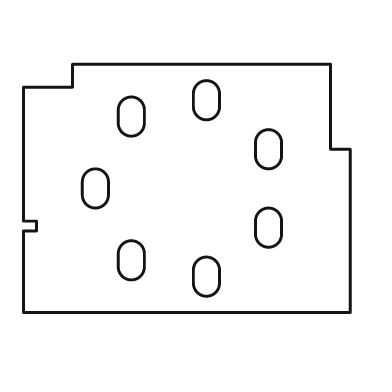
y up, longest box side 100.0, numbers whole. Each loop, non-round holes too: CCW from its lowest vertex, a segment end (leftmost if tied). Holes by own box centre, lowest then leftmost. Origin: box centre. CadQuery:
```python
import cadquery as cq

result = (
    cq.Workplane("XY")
    .moveTo(-50.0, -38.0)
    .lineTo(50.0, -38.0)
    .lineTo(50.0, 12.0)
    .lineTo(44.0, 12.0)
    .lineTo(44.0, 38.0)
    .lineTo(-35.0, 38.0)
    .lineTo(-35.0, 31.0)
    .lineTo(-50.0, 31.0)
    .lineTo(-50.0, -10.0)
    .lineTo(-46.0, -10.0)
    .lineTo(-46.0, -13.0)
    .lineTo(-50.0, -13.0)
    .close()
    .moveTo(2.0, -29.0)
    .threePointArc((6.0, -33.0), (10.0, -29.0))
    .lineTo(10.0, -25.0)
    .threePointArc((6.0, -21.0), (2.0, -25.0))
    .close()
    .moveTo(-21.0, -24.0)
    .threePointArc((-17.0, -28.0), (-13.0, -24.0))
    .lineTo(-13.0, -20.0)
    .threePointArc((-17.0, -16.0), (-21.0, -20.0))
    .close()
    .moveTo(21.0, -14.0)
    .threePointArc((25.0, -18.0), (29.0, -14.0))
    .lineTo(29.0, -10.0)
    .threePointArc((25.0, -6.0), (21.0, -10.0))
    .close()
    .moveTo(-32.0, -2.0)
    .threePointArc((-28.0, -6.0), (-24.0, -2.0))
    .lineTo(-24.0, 2.0)
    .threePointArc((-28.0, 6.0), (-32.0, 2.0))
    .close()
    .moveTo(21.0, 10.0)
    .threePointArc((25.0, 6.0), (29.0, 10.0))
    .lineTo(29.0, 14.0)
    .threePointArc((25.0, 18.0), (21.0, 14.0))
    .close()
    .moveTo(-21.0, 20.0)
    .threePointArc((-17.0, 16.0), (-13.0, 20.0))
    .lineTo(-13.0, 24.0)
    .threePointArc((-17.0, 28.0), (-21.0, 24.0))
    .close()
    .moveTo(2.0, 25.0)
    .threePointArc((6.0, 21.0), (10.0, 25.0))
    .lineTo(10.0, 29.0)
    .threePointArc((6.0, 33.0), (2.0, 29.0))
    .close()
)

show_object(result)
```